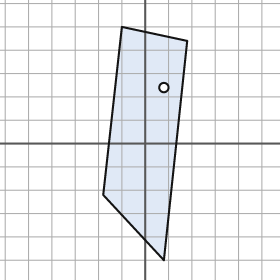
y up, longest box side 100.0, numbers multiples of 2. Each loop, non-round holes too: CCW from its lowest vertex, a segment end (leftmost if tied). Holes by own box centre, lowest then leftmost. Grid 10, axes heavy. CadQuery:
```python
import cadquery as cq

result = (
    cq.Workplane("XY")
    .moveTo(8.0, -50.0)
    .lineTo(18.0, 44.0)
    .lineTo(-10.0, 50.0)
    .lineTo(-18.0, -22.0)
    .close()
    .moveTo(8.0, 24.0)
    .circle(2.0)
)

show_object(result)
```